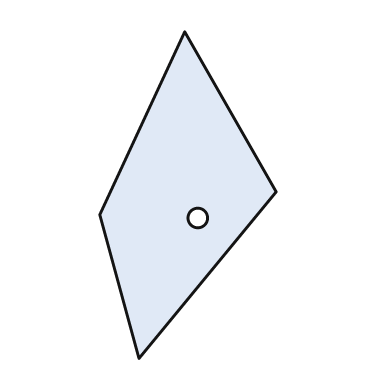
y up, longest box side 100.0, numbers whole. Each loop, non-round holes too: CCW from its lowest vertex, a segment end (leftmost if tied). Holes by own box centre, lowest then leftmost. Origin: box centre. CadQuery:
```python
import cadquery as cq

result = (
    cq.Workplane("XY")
    .moveTo(-15.0, -50.0)
    .lineTo(27.0, 1.0)
    .lineTo(-1.0, 50.0)
    .lineTo(-27.0, -6.0)
    .close()
    .moveTo(3.0, -7.0)
    .circle(3.0)
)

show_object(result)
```